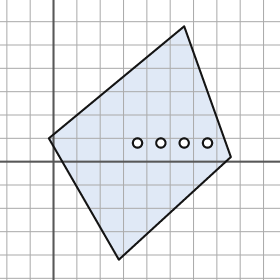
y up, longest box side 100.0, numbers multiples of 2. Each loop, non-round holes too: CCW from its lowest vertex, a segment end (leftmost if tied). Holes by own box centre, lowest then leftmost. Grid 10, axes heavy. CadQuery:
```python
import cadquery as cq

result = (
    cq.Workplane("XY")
    .moveTo(28.0, -42.0)
    .lineTo(76.0, 2.0)
    .lineTo(56.0, 58.0)
    .lineTo(-2.0, 10.0)
    .close()
    .moveTo(36.0, 8.0)
    .circle(2.0)
    .moveTo(46.0, 8.0)
    .circle(2.0)
    .moveTo(56.0, 8.0)
    .circle(2.0)
    .moveTo(66.0, 8.0)
    .circle(2.0)
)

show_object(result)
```